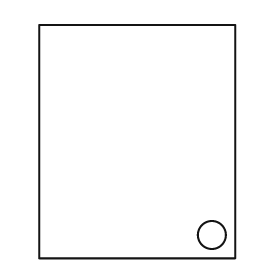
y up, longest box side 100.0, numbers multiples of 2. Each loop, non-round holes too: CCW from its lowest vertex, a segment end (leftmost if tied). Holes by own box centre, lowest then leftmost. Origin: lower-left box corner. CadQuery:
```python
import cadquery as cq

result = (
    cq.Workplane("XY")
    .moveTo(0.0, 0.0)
    .lineTo(84.0, 0.0)
    .lineTo(84.0, 100.0)
    .lineTo(0.0, 100.0)
    .close()
    .moveTo(74.0, 10.0)
    .circle(6.0)
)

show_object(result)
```